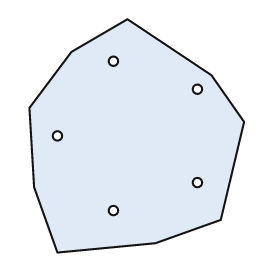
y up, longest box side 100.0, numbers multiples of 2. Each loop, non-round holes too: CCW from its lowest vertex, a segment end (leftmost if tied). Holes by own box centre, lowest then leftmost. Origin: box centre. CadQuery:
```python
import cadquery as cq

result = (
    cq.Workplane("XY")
    .moveTo(-34.0, -50.0)
    .lineTo(8.0, -46.0)
    .lineTo(36.0, -36.0)
    .lineTo(46.0, 6.0)
    .lineTo(32.0, 26.0)
    .lineTo(-4.0, 50.0)
    .lineTo(-28.0, 36.0)
    .lineTo(-46.0, 12.0)
    .lineTo(-44.0, -22.0)
    .close()
    .moveTo(-10.0, -32.0)
    .circle(2.0)
    .moveTo(26.0, -20.0)
    .circle(2.0)
    .moveTo(-34.0, 0.0)
    .circle(2.0)
    .moveTo(26.0, 20.0)
    .circle(2.0)
    .moveTo(-10.0, 32.0)
    .circle(2.0)
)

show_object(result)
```